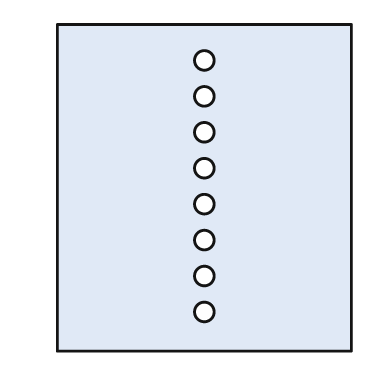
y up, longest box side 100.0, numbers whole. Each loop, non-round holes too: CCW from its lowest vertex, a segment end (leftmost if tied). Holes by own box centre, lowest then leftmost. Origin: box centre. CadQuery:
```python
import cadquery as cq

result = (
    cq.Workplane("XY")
    .moveTo(-45.0, -50.0)
    .lineTo(45.0, -50.0)
    .lineTo(45.0, 50.0)
    .lineTo(-45.0, 50.0)
    .close()
    .moveTo(0.0, -38.0)
    .circle(3.0)
    .moveTo(0.0, -27.0)
    .circle(3.0)
    .moveTo(0.0, -16.0)
    .circle(3.0)
    .moveTo(0.0, -5.0)
    .circle(3.0)
    .moveTo(0.0, 6.0)
    .circle(3.0)
    .moveTo(0.0, 17.0)
    .circle(3.0)
    .moveTo(0.0, 28.0)
    .circle(3.0)
    .moveTo(0.0, 39.0)
    .circle(3.0)
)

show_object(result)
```